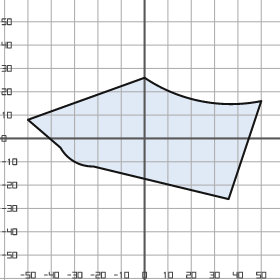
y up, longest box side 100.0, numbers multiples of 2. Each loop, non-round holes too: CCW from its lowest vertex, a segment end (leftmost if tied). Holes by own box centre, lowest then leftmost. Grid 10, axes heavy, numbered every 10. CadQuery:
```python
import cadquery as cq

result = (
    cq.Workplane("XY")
    .moveTo(36.0, -26.0)
    .lineTo(50.0, 16.0)
    .threePointArc((24.0, 16.0), (0.0, 26.0))
    .lineTo(-50.0, 8.0)
    .lineTo(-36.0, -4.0)
    .threePointArc((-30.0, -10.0), (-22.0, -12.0))
    .close()
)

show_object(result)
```